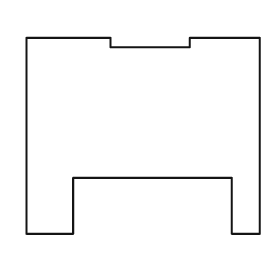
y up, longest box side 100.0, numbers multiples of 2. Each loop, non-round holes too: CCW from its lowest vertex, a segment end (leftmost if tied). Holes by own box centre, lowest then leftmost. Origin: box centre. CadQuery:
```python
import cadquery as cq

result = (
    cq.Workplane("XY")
    .moveTo(-50.0, -42.0)
    .lineTo(-30.0, -42.0)
    .lineTo(-30.0, -18.0)
    .lineTo(38.0, -18.0)
    .lineTo(38.0, -42.0)
    .lineTo(50.0, -42.0)
    .lineTo(50.0, 42.0)
    .lineTo(20.0, 42.0)
    .lineTo(20.0, 38.0)
    .lineTo(-14.0, 38.0)
    .lineTo(-14.0, 42.0)
    .lineTo(-50.0, 42.0)
    .close()
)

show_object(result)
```